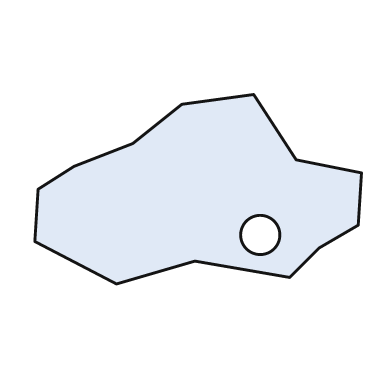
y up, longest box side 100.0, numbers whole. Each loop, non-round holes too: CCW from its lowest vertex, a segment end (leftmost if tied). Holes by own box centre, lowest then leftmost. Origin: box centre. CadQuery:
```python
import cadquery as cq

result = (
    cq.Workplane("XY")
    .moveTo(-25.0, -29.0)
    .lineTo(-1.0, -22.0)
    .lineTo(28.0, -27.0)
    .lineTo(37.0, -18.0)
    .lineTo(49.0, -11.0)
    .lineTo(50.0, 5.0)
    .lineTo(30.0, 9.0)
    .lineTo(17.0, 29.0)
    .lineTo(-5.0, 26.0)
    .lineTo(-20.0, 14.0)
    .lineTo(-38.0, 7.0)
    .lineTo(-49.0, 0.0)
    .lineTo(-50.0, -16.0)
    .close()
    .moveTo(19.0, -14.0)
    .circle(6.0)
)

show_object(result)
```